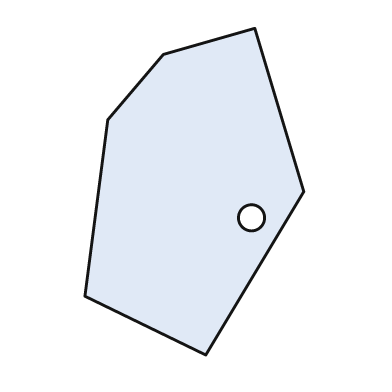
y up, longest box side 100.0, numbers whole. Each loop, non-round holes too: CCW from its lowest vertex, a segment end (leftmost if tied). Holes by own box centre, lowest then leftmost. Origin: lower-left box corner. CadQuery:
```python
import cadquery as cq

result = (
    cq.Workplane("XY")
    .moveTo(37.0, 0.0)
    .lineTo(67.0, 50.0)
    .lineTo(52.0, 100.0)
    .lineTo(24.0, 92.0)
    .lineTo(7.0, 72.0)
    .lineTo(0.0, 18.0)
    .close()
    .moveTo(51.0, 42.0)
    .circle(4.0)
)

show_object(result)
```